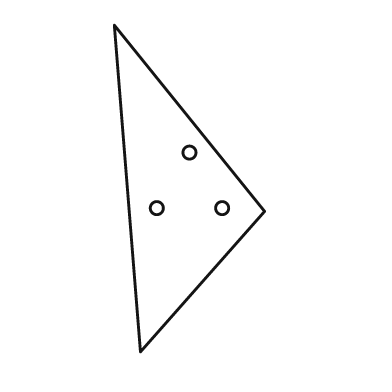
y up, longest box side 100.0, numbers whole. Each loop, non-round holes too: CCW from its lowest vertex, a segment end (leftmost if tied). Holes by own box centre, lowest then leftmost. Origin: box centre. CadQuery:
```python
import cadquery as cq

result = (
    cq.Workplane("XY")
    .moveTo(-15.0, -50.0)
    .lineTo(23.0, -7.0)
    .lineTo(-23.0, 50.0)
    .close()
    .moveTo(-10.0, -6.0)
    .circle(2.0)
    .moveTo(10.0, -6.0)
    .circle(2.0)
    .moveTo(0.0, 11.0)
    .circle(2.0)
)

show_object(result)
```